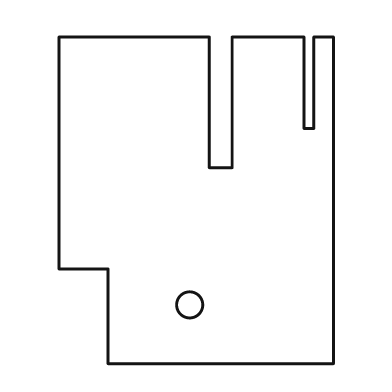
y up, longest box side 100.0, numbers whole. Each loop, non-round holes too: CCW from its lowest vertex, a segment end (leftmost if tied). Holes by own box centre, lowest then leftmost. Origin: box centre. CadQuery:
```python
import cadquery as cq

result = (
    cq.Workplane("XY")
    .moveTo(-27.0, -50.0)
    .lineTo(42.0, -50.0)
    .lineTo(42.0, 50.0)
    .lineTo(36.0, 50.0)
    .lineTo(36.0, 22.0)
    .lineTo(33.0, 22.0)
    .lineTo(33.0, 50.0)
    .lineTo(11.0, 50.0)
    .lineTo(11.0, 10.0)
    .lineTo(4.0, 10.0)
    .lineTo(4.0, 50.0)
    .lineTo(-42.0, 50.0)
    .lineTo(-42.0, -21.0)
    .lineTo(-27.0, -21.0)
    .close()
    .moveTo(-2.0, -32.0)
    .circle(4.0)
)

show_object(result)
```